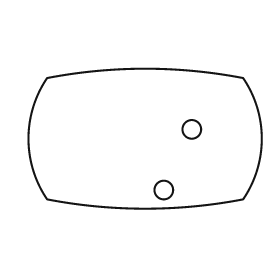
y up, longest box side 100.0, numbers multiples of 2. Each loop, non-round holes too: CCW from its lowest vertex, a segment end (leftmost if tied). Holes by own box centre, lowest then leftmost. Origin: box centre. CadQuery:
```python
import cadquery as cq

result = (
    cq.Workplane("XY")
    .moveTo(-42.0, -26.0)
    .threePointArc((0.0, -30.0), (42.0, -26.0))
    .threePointArc((50.0, 0.0), (42.0, 26.0))
    .threePointArc((0.0, 30.0), (-42.0, 26.0))
    .threePointArc((-50.0, 0.0), (-42.0, -26.0))
    .close()
    .moveTo(8.0, -22.0)
    .circle(4.0)
    .moveTo(20.0, 4.0)
    .circle(4.0)
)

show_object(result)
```